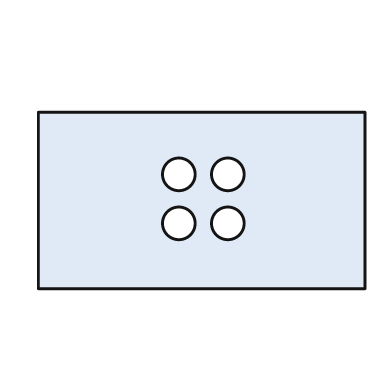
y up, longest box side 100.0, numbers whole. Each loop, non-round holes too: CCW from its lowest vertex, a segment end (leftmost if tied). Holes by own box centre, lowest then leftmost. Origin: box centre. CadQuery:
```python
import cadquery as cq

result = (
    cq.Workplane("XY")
    .moveTo(-50.0, -27.0)
    .lineTo(50.0, -27.0)
    .lineTo(50.0, 27.0)
    .lineTo(-50.0, 27.0)
    .close()
    .moveTo(-7.0, -7.0)
    .circle(5.0)
    .moveTo(8.0, -7.0)
    .circle(5.0)
    .moveTo(-7.0, 8.0)
    .circle(5.0)
    .moveTo(8.0, 8.0)
    .circle(5.0)
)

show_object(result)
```